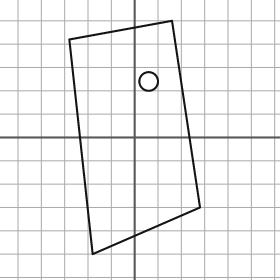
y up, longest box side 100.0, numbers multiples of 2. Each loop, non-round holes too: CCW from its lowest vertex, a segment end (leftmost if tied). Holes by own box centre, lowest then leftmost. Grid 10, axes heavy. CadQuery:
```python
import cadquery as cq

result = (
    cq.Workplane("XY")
    .moveTo(-18.0, -50.0)
    .lineTo(28.0, -30.0)
    .lineTo(16.0, 50.0)
    .lineTo(-28.0, 42.0)
    .close()
    .moveTo(6.0, 24.0)
    .circle(4.0)
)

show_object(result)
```